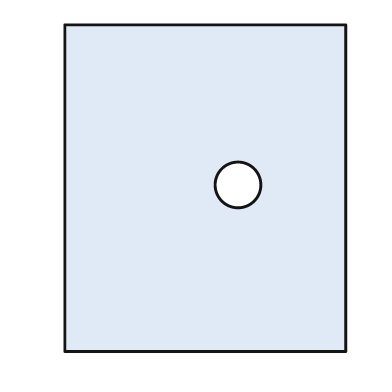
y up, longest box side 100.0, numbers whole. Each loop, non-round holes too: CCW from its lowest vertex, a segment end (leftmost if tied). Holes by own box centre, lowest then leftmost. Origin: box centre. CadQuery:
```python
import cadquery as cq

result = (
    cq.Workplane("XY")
    .moveTo(-43.0, -50.0)
    .lineTo(43.0, -50.0)
    .lineTo(43.0, 50.0)
    .lineTo(-43.0, 50.0)
    .close()
    .moveTo(10.0, 1.0)
    .circle(7.0)
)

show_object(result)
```